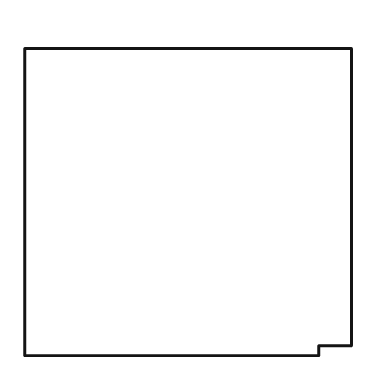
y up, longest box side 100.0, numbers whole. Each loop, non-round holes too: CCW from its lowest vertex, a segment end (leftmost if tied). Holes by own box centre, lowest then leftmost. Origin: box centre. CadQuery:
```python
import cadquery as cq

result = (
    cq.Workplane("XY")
    .moveTo(-50.0, -47.0)
    .lineTo(40.0, -47.0)
    .lineTo(40.0, -44.0)
    .lineTo(50.0, -44.0)
    .lineTo(50.0, 47.0)
    .lineTo(-50.0, 47.0)
    .close()
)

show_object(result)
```